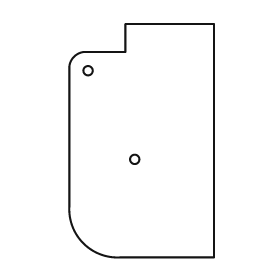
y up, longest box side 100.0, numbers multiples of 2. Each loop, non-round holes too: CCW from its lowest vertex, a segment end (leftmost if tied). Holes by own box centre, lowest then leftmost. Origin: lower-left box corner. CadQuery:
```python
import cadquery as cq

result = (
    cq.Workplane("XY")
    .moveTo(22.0, 0.0)
    .lineTo(62.0, 0.0)
    .lineTo(62.0, 100.0)
    .lineTo(24.0, 100.0)
    .lineTo(24.0, 88.0)
    .lineTo(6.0, 88.0)
    .threePointArc((2.0, 86.0), (0.0, 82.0))
    .lineTo(0.0, 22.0)
    .threePointArc((6.0, 6.0), (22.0, 0.0))
    .close()
    .moveTo(28.0, 42.0)
    .circle(2.0)
    .moveTo(8.0, 80.0)
    .circle(2.0)
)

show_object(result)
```